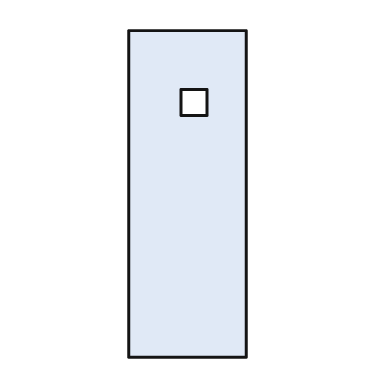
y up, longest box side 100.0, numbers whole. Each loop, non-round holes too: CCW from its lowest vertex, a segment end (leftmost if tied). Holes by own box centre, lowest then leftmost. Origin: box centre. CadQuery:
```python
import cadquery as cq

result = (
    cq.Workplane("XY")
    .moveTo(-18.0, -50.0)
    .lineTo(18.0, -50.0)
    .lineTo(18.0, 50.0)
    .lineTo(-18.0, 50.0)
    .close()
    .moveTo(-2.0, 24.0)
    .lineTo(6.0, 24.0)
    .lineTo(6.0, 32.0)
    .lineTo(-2.0, 32.0)
    .close()
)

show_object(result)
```